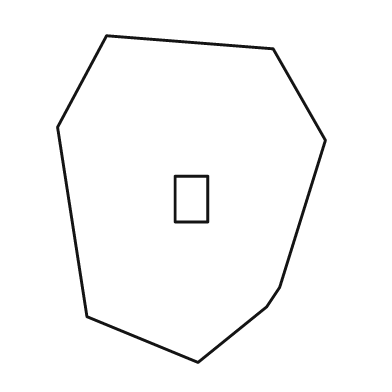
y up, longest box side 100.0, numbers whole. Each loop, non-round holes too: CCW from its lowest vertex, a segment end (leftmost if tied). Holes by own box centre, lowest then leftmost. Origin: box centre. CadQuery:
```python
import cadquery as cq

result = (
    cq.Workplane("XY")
    .moveTo(2.0, -50.0)
    .lineTo(23.0, -33.0)
    .lineTo(27.0, -27.0)
    .lineTo(41.0, 18.0)
    .lineTo(25.0, 46.0)
    .lineTo(-26.0, 50.0)
    .lineTo(-41.0, 22.0)
    .lineTo(-32.0, -36.0)
    .close()
    .moveTo(-5.0, -7.0)
    .lineTo(5.0, -7.0)
    .lineTo(5.0, 7.0)
    .lineTo(-5.0, 7.0)
    .close()
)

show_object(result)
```